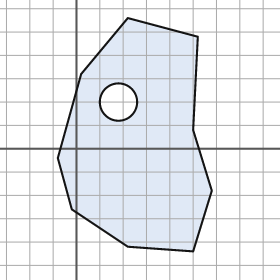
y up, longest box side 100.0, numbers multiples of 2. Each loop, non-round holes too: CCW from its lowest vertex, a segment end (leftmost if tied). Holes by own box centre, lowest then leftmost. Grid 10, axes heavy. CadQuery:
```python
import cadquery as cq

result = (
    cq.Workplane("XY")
    .moveTo(50.0, -44.0)
    .lineTo(58.0, -18.0)
    .lineTo(50.0, 8.0)
    .lineTo(52.0, 48.0)
    .lineTo(22.0, 56.0)
    .lineTo(2.0, 32.0)
    .lineTo(-8.0, -4.0)
    .lineTo(-2.0, -26.0)
    .lineTo(22.0, -42.0)
    .close()
    .moveTo(18.0, 20.0)
    .circle(8.0)
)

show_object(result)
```